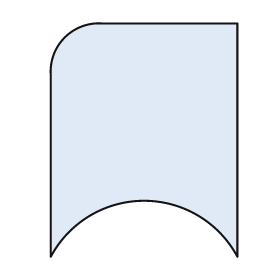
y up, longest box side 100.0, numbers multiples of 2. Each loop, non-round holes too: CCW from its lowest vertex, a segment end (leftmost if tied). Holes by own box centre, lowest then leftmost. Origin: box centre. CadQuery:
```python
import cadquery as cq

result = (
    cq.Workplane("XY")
    .moveTo(-40.0, -50.0)
    .threePointArc((0.0, -26.0), (40.0, -50.0))
    .lineTo(40.0, 50.0)
    .lineTo(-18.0, 50.0)
    .threePointArc((-34.0, 44.0), (-40.0, 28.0))
    .close()
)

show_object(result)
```